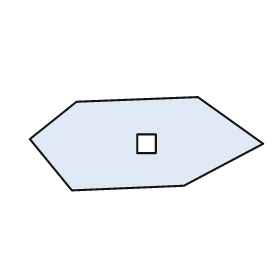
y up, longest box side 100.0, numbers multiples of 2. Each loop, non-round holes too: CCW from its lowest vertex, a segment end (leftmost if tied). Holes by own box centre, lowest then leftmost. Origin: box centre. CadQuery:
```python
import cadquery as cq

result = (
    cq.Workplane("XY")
    .moveTo(-32.0, -20.0)
    .lineTo(16.0, -18.0)
    .lineTo(50.0, 0.0)
    .lineTo(22.0, 20.0)
    .lineTo(-30.0, 18.0)
    .lineTo(-50.0, 2.0)
    .close()
    .moveTo(-4.0, -4.0)
    .lineTo(4.0, -4.0)
    .lineTo(4.0, 4.0)
    .lineTo(-4.0, 4.0)
    .close()
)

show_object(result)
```